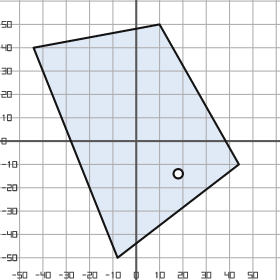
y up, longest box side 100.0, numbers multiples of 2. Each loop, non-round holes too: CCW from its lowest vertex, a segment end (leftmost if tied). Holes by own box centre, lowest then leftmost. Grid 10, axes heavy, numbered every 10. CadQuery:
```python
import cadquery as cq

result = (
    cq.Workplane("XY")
    .moveTo(-8.0, -50.0)
    .lineTo(44.0, -10.0)
    .lineTo(10.0, 50.0)
    .lineTo(-44.0, 40.0)
    .close()
    .moveTo(18.0, -14.0)
    .circle(2.0)
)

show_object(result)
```